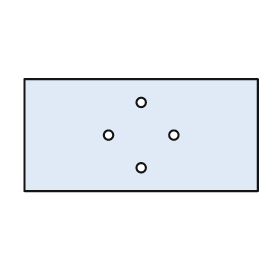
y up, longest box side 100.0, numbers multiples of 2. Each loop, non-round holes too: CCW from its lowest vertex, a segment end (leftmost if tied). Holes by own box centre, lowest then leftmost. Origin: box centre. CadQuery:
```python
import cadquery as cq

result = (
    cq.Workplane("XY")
    .moveTo(-50.0, -24.0)
    .lineTo(50.0, -24.0)
    .lineTo(50.0, 24.0)
    .lineTo(-50.0, 24.0)
    .close()
    .moveTo(0.0, -14.0)
    .circle(2.0)
    .moveTo(-14.0, 0.0)
    .circle(2.0)
    .moveTo(14.0, 0.0)
    .circle(2.0)
    .moveTo(0.0, 14.0)
    .circle(2.0)
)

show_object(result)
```